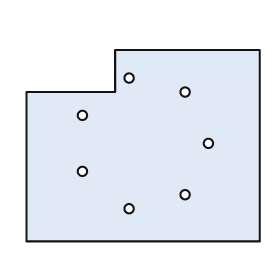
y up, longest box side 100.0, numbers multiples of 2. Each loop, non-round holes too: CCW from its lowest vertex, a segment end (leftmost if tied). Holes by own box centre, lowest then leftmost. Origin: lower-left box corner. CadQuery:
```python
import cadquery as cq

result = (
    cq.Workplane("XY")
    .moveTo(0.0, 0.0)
    .lineTo(100.0, 0.0)
    .lineTo(100.0, 82.0)
    .lineTo(38.0, 82.0)
    .lineTo(38.0, 64.0)
    .lineTo(0.0, 64.0)
    .close()
    .moveTo(44.0, 14.0)
    .circle(2.0)
    .moveTo(68.0, 20.0)
    .circle(2.0)
    .moveTo(24.0, 30.0)
    .circle(2.0)
    .moveTo(78.0, 42.0)
    .circle(2.0)
    .moveTo(24.0, 54.0)
    .circle(2.0)
    .moveTo(68.0, 64.0)
    .circle(2.0)
    .moveTo(44.0, 70.0)
    .circle(2.0)
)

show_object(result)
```